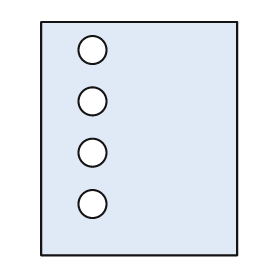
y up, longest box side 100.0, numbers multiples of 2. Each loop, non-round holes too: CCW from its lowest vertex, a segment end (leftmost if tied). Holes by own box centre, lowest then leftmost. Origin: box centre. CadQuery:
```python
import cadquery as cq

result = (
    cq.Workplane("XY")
    .moveTo(-42.0, -50.0)
    .lineTo(42.0, -50.0)
    .lineTo(42.0, 50.0)
    .lineTo(-42.0, 50.0)
    .close()
    .moveTo(-20.0, -28.0)
    .circle(6.0)
    .moveTo(-20.0, -6.0)
    .circle(6.0)
    .moveTo(-20.0, 16.0)
    .circle(6.0)
    .moveTo(-20.0, 38.0)
    .circle(6.0)
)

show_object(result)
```